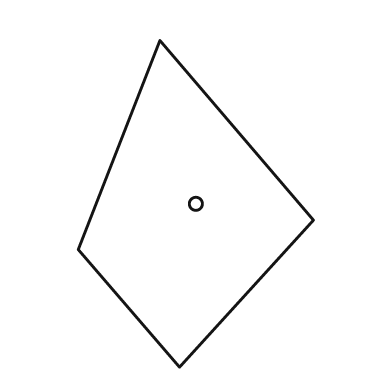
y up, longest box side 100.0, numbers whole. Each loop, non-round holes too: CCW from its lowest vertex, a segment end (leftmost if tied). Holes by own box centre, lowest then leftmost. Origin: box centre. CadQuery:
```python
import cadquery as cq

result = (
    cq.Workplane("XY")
    .moveTo(-5.0, -50.0)
    .lineTo(36.0, -5.0)
    .lineTo(-11.0, 50.0)
    .lineTo(-36.0, -14.0)
    .close()
    .moveTo(0.0, 0.0)
    .circle(2.0)
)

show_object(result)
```